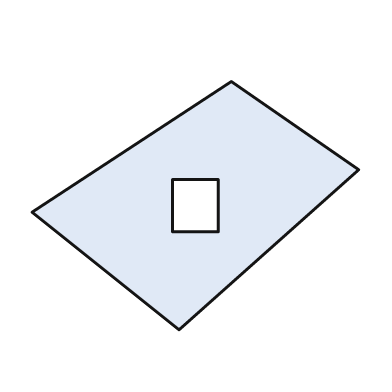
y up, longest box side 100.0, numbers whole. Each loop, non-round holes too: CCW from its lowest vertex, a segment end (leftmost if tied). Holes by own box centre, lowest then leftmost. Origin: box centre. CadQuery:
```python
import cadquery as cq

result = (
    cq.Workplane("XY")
    .moveTo(-5.0, -38.0)
    .lineTo(50.0, 11.0)
    .lineTo(11.0, 38.0)
    .lineTo(-50.0, -2.0)
    .close()
    .moveTo(-7.0, -8.0)
    .lineTo(7.0, -8.0)
    .lineTo(7.0, 8.0)
    .lineTo(-7.0, 8.0)
    .close()
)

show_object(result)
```